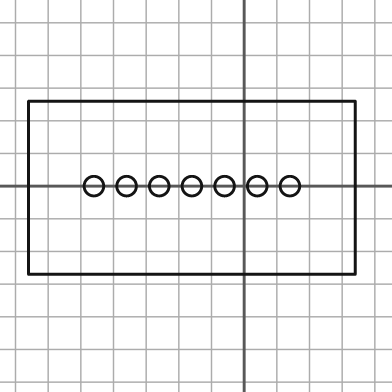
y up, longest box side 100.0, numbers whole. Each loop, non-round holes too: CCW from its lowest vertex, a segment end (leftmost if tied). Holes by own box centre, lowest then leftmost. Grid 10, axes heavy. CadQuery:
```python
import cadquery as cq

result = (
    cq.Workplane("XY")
    .moveTo(-66.0, -27.0)
    .lineTo(34.0, -27.0)
    .lineTo(34.0, 26.0)
    .lineTo(-66.0, 26.0)
    .close()
    .moveTo(-46.0, 0.0)
    .circle(3.0)
    .moveTo(-36.0, 0.0)
    .circle(3.0)
    .moveTo(-26.0, 0.0)
    .circle(3.0)
    .moveTo(-16.0, 0.0)
    .circle(3.0)
    .moveTo(-6.0, 0.0)
    .circle(3.0)
    .moveTo(4.0, 0.0)
    .circle(3.0)
    .moveTo(14.0, 0.0)
    .circle(3.0)
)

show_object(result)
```